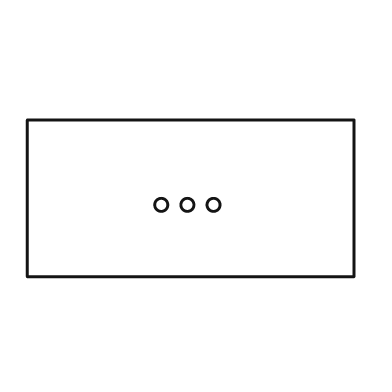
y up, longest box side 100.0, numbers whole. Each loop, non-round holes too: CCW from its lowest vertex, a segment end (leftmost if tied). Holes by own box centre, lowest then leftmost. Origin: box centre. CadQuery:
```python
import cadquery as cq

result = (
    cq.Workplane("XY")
    .moveTo(-50.0, -24.0)
    .lineTo(50.0, -24.0)
    .lineTo(50.0, 24.0)
    .lineTo(-50.0, 24.0)
    .close()
    .moveTo(-9.0, -2.0)
    .circle(2.0)
    .moveTo(-1.0, -2.0)
    .circle(2.0)
    .moveTo(7.0, -2.0)
    .circle(2.0)
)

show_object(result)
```